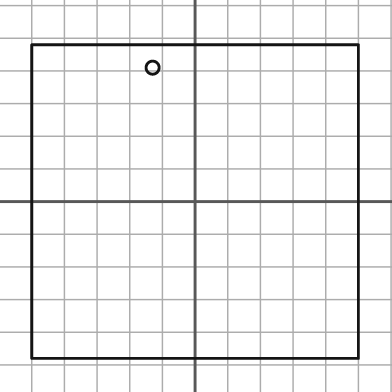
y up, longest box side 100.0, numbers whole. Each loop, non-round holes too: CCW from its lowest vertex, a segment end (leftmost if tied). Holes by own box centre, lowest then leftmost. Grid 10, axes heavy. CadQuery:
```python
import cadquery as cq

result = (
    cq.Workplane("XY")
    .moveTo(-50.0, -48.0)
    .lineTo(50.0, -48.0)
    .lineTo(50.0, 48.0)
    .lineTo(-50.0, 48.0)
    .close()
    .moveTo(-13.0, 41.0)
    .circle(2.0)
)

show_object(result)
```